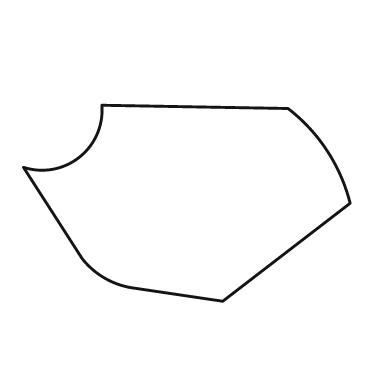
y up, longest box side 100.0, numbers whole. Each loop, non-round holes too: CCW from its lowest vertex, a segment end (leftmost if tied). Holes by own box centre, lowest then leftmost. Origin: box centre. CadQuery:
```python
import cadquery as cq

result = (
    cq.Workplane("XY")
    .moveTo(11.0, -30.0)
    .lineTo(50.0, 0.0)
    .threePointArc((43.0, 16.0), (31.0, 29.0))
    .lineTo(-26.0, 30.0)
    .threePointArc((-33.0, 14.0), (-50.0, 11.0))
    .lineTo(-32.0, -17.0)
    .threePointArc((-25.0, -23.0), (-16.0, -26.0))
    .close()
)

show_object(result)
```